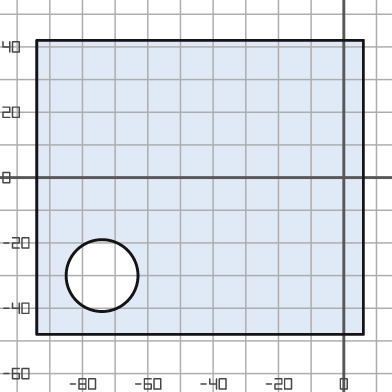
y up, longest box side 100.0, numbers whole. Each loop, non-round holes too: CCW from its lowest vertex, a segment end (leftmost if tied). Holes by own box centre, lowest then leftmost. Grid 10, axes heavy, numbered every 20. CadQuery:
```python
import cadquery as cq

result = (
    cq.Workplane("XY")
    .moveTo(-94.0, -48.0)
    .lineTo(6.0, -48.0)
    .lineTo(6.0, 42.0)
    .lineTo(-94.0, 42.0)
    .close()
    .moveTo(-74.0, -30.0)
    .circle(11.0)
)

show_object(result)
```